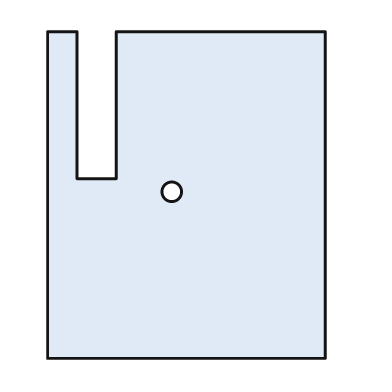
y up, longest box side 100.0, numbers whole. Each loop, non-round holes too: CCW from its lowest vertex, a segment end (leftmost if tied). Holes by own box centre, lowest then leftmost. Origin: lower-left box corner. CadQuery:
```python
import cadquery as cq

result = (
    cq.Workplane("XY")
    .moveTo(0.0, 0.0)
    .lineTo(85.0, 0.0)
    .lineTo(85.0, 100.0)
    .lineTo(21.0, 100.0)
    .lineTo(21.0, 55.0)
    .lineTo(9.0, 55.0)
    .lineTo(9.0, 100.0)
    .lineTo(0.0, 100.0)
    .close()
    .moveTo(38.0, 51.0)
    .circle(3.0)
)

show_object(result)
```